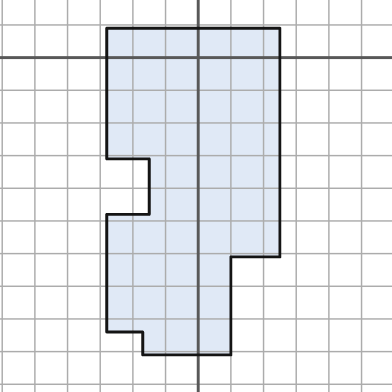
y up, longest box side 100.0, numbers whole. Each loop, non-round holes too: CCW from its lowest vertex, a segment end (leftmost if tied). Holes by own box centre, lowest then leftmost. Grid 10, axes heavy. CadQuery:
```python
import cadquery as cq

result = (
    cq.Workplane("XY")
    .moveTo(-17.0, -91.0)
    .lineTo(10.0, -91.0)
    .lineTo(10.0, -61.0)
    .lineTo(25.0, -61.0)
    .lineTo(25.0, 9.0)
    .lineTo(-28.0, 9.0)
    .lineTo(-28.0, -31.0)
    .lineTo(-15.0, -31.0)
    .lineTo(-15.0, -48.0)
    .lineTo(-28.0, -48.0)
    .lineTo(-28.0, -84.0)
    .lineTo(-17.0, -84.0)
    .close()
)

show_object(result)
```